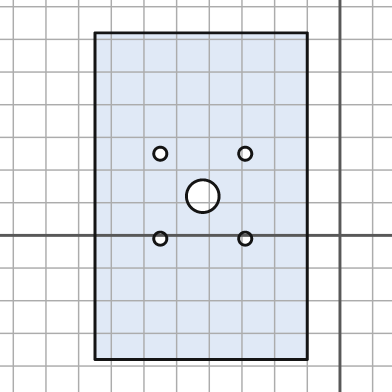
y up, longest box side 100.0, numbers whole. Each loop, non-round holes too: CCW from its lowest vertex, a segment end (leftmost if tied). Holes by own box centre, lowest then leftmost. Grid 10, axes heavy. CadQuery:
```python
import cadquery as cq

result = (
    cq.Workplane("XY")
    .moveTo(-75.0, -38.0)
    .lineTo(-10.0, -38.0)
    .lineTo(-10.0, 62.0)
    .lineTo(-75.0, 62.0)
    .close()
    .moveTo(-55.0, -1.0)
    .circle(2.0)
    .moveTo(-29.0, -1.0)
    .circle(2.0)
    .moveTo(-42.0, 12.0)
    .circle(5.0)
    .moveTo(-55.0, 25.0)
    .circle(2.0)
    .moveTo(-29.0, 25.0)
    .circle(2.0)
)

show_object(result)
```